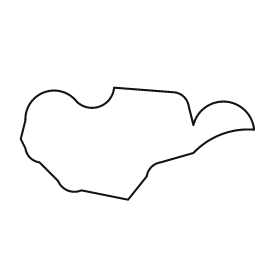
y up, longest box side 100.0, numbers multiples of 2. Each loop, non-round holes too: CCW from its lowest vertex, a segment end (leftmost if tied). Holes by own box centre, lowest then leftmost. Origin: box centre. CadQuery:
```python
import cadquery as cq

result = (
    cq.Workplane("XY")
    .moveTo(-4.0, -24.0)
    .lineTo(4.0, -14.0)
    .threePointArc((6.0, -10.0), (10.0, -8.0))
    .lineTo(24.0, -4.0)
    .threePointArc((36.0, 4.0), (50.0, 6.0))
    .threePointArc((38.0, 18.0), (24.0, 8.0))
    .lineTo(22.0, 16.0)
    .threePointArc((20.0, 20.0), (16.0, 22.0))
    .lineTo(-10.0, 24.0)
    .threePointArc((-16.0, 16.0), (-26.0, 18.0))
    .threePointArc((-40.0, 22.0), (-48.0, 10.0))
    .lineTo(-50.0, 2.0)
    .lineTo(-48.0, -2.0)
    .threePointArc((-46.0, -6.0), (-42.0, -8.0))
    .lineTo(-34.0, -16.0)
    .threePointArc((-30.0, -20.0), (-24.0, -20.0))
    .close()
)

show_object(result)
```